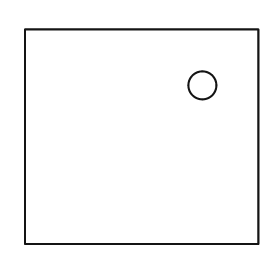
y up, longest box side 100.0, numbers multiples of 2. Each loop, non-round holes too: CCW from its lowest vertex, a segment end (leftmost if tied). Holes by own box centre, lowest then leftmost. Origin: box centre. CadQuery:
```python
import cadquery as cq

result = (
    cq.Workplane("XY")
    .moveTo(-50.0, -46.0)
    .lineTo(50.0, -46.0)
    .lineTo(50.0, 46.0)
    .lineTo(-50.0, 46.0)
    .close()
    .moveTo(26.0, 22.0)
    .circle(6.0)
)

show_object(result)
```